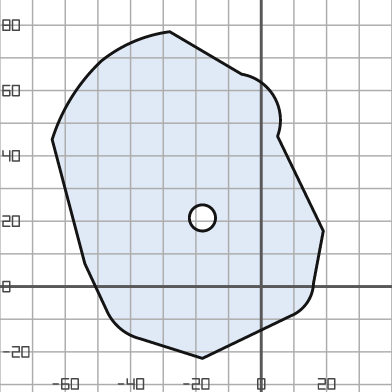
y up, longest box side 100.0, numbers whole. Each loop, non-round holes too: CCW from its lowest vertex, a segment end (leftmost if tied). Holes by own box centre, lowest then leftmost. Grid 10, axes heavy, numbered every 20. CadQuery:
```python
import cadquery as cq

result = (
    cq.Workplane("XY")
    .moveTo(-18.0, -22.0)
    .lineTo(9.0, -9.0)
    .threePointArc((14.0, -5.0), (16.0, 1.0))
    .lineTo(19.0, 17.0)
    .lineTo(5.0, 46.0)
    .threePointArc((4.0, 58.0), (-6.0, 65.0))
    .lineTo(-28.0, 78.0)
    .threePointArc((-39.0, 75.0), (-49.0, 69.0))
    .threePointArc((-58.0, 58.0), (-64.0, 45.0))
    .lineTo(-54.0, 7.0)
    .lineTo(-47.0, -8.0)
    .threePointArc((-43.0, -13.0), (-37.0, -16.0))
    .close()
    .moveTo(-18.0, 21.0)
    .circle(4.0)
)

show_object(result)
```